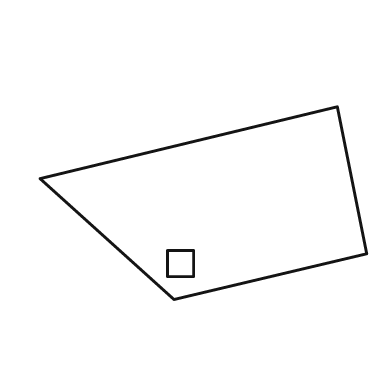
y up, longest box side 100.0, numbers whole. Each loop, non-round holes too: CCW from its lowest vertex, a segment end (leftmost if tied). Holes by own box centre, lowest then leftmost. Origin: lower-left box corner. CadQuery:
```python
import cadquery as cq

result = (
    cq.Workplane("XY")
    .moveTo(41.0, 0.0)
    .lineTo(100.0, 14.0)
    .lineTo(91.0, 59.0)
    .lineTo(0.0, 37.0)
    .close()
    .moveTo(39.0, 7.0)
    .lineTo(47.0, 7.0)
    .lineTo(47.0, 15.0)
    .lineTo(39.0, 15.0)
    .close()
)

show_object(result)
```